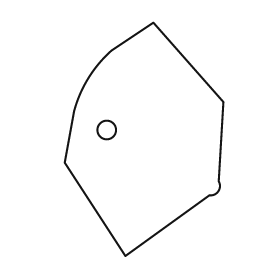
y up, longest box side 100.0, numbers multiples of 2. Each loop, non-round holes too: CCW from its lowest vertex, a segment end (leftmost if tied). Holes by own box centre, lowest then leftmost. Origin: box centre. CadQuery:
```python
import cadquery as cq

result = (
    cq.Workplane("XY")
    .moveTo(-8.0, -50.0)
    .lineTo(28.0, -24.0)
    .threePointArc((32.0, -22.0), (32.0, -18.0))
    .lineTo(34.0, 16.0)
    .lineTo(4.0, 50.0)
    .lineTo(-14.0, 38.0)
    .threePointArc((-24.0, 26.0), (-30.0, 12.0))
    .lineTo(-34.0, -10.0)
    .close()
    .moveTo(-16.0, 4.0)
    .circle(4.0)
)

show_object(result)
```